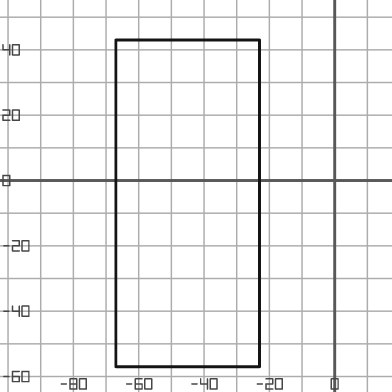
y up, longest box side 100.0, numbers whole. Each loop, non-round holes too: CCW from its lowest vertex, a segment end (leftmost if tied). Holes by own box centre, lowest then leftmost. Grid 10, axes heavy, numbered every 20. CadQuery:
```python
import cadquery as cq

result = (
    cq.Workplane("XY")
    .moveTo(-67.0, -57.0)
    .lineTo(-23.0, -57.0)
    .lineTo(-23.0, 43.0)
    .lineTo(-67.0, 43.0)
    .close()
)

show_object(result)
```